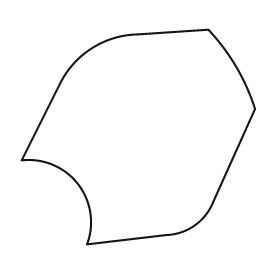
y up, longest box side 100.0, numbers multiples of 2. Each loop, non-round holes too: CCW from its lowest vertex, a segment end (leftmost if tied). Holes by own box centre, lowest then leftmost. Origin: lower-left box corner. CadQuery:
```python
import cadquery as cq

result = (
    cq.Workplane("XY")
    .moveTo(28.0, 0.0)
    .lineTo(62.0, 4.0)
    .threePointArc((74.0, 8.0), (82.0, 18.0))
    .lineTo(100.0, 58.0)
    .threePointArc((92.0, 76.0), (80.0, 92.0))
    .lineTo(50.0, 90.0)
    .threePointArc((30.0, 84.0), (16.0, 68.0))
    .lineTo(0.0, 36.0)
    .threePointArc((24.0, 26.0), (28.0, 0.0))
    .close()
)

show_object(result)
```